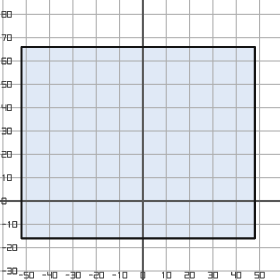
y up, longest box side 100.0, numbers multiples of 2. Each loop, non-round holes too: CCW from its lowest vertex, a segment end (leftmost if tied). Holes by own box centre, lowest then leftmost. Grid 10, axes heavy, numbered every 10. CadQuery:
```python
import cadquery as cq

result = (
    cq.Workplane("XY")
    .moveTo(-52.0, -16.0)
    .lineTo(48.0, -16.0)
    .lineTo(48.0, 66.0)
    .lineTo(-52.0, 66.0)
    .close()
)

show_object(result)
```